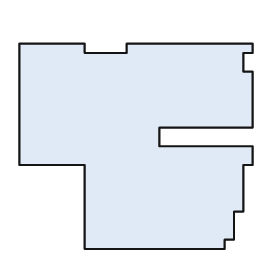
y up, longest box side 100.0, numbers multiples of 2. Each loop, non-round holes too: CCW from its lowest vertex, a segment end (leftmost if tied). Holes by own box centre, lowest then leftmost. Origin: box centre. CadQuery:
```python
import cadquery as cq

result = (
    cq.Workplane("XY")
    .moveTo(-22.0, -44.0)
    .lineTo(38.0, -44.0)
    .lineTo(38.0, -40.0)
    .lineTo(42.0, -40.0)
    .lineTo(42.0, -28.0)
    .lineTo(46.0, -28.0)
    .lineTo(46.0, -8.0)
    .lineTo(50.0, -8.0)
    .lineTo(50.0, 0.0)
    .lineTo(10.0, 0.0)
    .lineTo(10.0, 8.0)
    .lineTo(50.0, 8.0)
    .lineTo(50.0, 32.0)
    .lineTo(46.0, 32.0)
    .lineTo(46.0, 40.0)
    .lineTo(50.0, 40.0)
    .lineTo(50.0, 44.0)
    .lineTo(-4.0, 44.0)
    .lineTo(-4.0, 40.0)
    .lineTo(-22.0, 40.0)
    .lineTo(-22.0, 44.0)
    .lineTo(-50.0, 44.0)
    .lineTo(-50.0, -8.0)
    .lineTo(-22.0, -8.0)
    .close()
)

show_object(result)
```